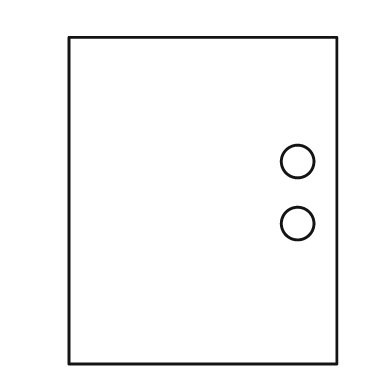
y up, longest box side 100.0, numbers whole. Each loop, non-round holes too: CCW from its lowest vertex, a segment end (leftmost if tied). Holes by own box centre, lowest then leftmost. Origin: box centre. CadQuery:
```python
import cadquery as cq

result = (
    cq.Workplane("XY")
    .moveTo(-41.0, -50.0)
    .lineTo(41.0, -50.0)
    .lineTo(41.0, 50.0)
    .lineTo(-41.0, 50.0)
    .close()
    .moveTo(29.0, -7.0)
    .circle(5.0)
    .moveTo(29.0, 12.0)
    .circle(5.0)
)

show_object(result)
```